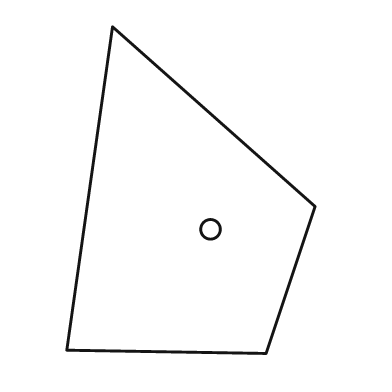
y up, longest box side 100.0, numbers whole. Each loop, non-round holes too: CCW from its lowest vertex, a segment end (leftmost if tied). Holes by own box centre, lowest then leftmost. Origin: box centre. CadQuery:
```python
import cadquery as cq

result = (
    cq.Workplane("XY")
    .moveTo(23.0, -50.0)
    .lineTo(38.0, -5.0)
    .lineTo(-24.0, 50.0)
    .lineTo(-38.0, -49.0)
    .close()
    .moveTo(6.0, -12.0)
    .circle(3.0)
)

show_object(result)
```